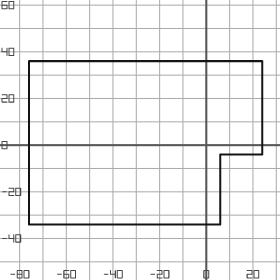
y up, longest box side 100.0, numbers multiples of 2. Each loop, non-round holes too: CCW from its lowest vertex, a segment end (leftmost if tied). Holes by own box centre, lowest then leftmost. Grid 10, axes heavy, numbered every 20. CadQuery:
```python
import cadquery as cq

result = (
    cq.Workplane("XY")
    .moveTo(-76.0, -34.0)
    .lineTo(6.0, -34.0)
    .lineTo(6.0, -4.0)
    .lineTo(24.0, -4.0)
    .lineTo(24.0, 36.0)
    .lineTo(-76.0, 36.0)
    .close()
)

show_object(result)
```